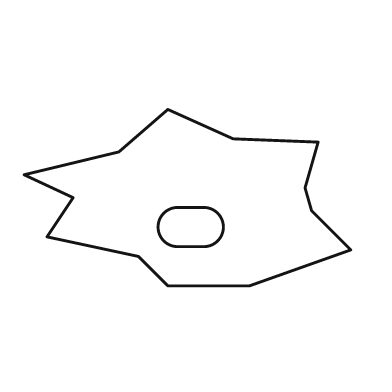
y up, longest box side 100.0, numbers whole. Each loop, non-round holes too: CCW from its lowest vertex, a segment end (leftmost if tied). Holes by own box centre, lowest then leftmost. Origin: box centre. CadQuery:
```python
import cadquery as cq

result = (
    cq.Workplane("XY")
    .moveTo(-6.0, -27.0)
    .lineTo(19.0, -27.0)
    .lineTo(50.0, -16.0)
    .lineTo(38.0, -4.0)
    .lineTo(36.0, 3.0)
    .lineTo(40.0, 17.0)
    .lineTo(14.0, 18.0)
    .lineTo(-6.0, 27.0)
    .lineTo(-21.0, 14.0)
    .lineTo(-50.0, 7.0)
    .lineTo(-35.0, 0.0)
    .lineTo(-43.0, -12.0)
    .lineTo(-15.0, -18.0)
    .close()
    .moveTo(-3.0, -15.0)
    .lineTo(5.0, -15.0)
    .threePointArc((11.0, -9.0), (5.0, -3.0))
    .lineTo(-3.0, -3.0)
    .threePointArc((-9.0, -9.0), (-3.0, -15.0))
    .close()
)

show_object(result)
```